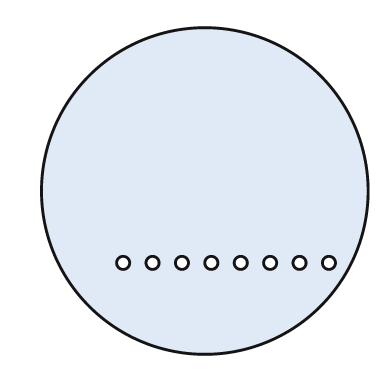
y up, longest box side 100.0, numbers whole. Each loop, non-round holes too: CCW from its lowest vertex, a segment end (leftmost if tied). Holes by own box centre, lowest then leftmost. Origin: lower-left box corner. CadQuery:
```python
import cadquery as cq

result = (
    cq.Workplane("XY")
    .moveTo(50.0, 50.0)
    .circle(50.0)
    .moveTo(25.0, 28.0)
    .circle(2.0)
    .moveTo(34.0, 28.0)
    .circle(2.0)
    .moveTo(43.0, 28.0)
    .circle(2.0)
    .moveTo(52.0, 28.0)
    .circle(2.0)
    .moveTo(61.0, 28.0)
    .circle(2.0)
    .moveTo(70.0, 28.0)
    .circle(2.0)
    .moveTo(79.0, 28.0)
    .circle(2.0)
    .moveTo(88.0, 28.0)
    .circle(2.0)
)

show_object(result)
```